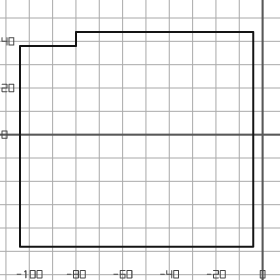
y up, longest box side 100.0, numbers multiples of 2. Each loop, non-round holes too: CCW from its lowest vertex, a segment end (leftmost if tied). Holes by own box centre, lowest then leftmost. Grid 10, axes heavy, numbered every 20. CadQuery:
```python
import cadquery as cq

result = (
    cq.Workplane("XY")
    .moveTo(-104.0, -48.0)
    .lineTo(-4.0, -48.0)
    .lineTo(-4.0, 44.0)
    .lineTo(-80.0, 44.0)
    .lineTo(-80.0, 38.0)
    .lineTo(-104.0, 38.0)
    .close()
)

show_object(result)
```